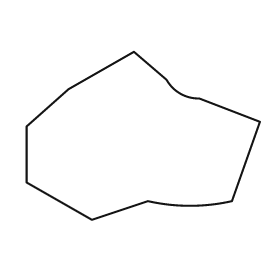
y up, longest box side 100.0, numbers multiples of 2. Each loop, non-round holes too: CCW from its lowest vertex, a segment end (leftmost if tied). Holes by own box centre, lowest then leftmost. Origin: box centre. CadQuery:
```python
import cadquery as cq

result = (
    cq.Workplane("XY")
    .moveTo(-22.0, -36.0)
    .lineTo(2.0, -28.0)
    .threePointArc((20.0, -30.0), (38.0, -28.0))
    .lineTo(50.0, 6.0)
    .lineTo(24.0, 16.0)
    .threePointArc((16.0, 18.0), (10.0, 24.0))
    .lineTo(-4.0, 36.0)
    .lineTo(-32.0, 20.0)
    .lineTo(-50.0, 4.0)
    .lineTo(-50.0, -20.0)
    .close()
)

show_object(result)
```